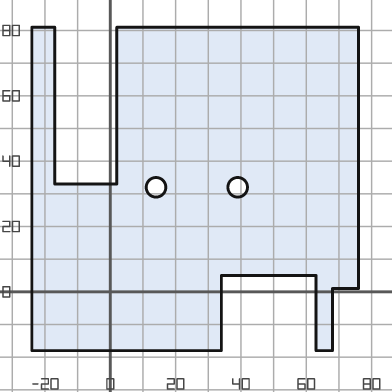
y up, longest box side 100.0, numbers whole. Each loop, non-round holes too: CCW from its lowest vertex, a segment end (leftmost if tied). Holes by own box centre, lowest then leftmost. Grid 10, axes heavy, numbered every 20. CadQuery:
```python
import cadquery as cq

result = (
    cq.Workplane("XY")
    .moveTo(-24.0, -18.0)
    .lineTo(34.0, -18.0)
    .lineTo(34.0, 5.0)
    .lineTo(63.0, 5.0)
    .lineTo(63.0, -18.0)
    .lineTo(68.0, -18.0)
    .lineTo(68.0, 1.0)
    .lineTo(76.0, 1.0)
    .lineTo(76.0, 81.0)
    .lineTo(2.0, 81.0)
    .lineTo(2.0, 33.0)
    .lineTo(-17.0, 33.0)
    .lineTo(-17.0, 81.0)
    .lineTo(-24.0, 81.0)
    .close()
    .moveTo(14.0, 32.0)
    .circle(3.0)
    .moveTo(39.0, 32.0)
    .circle(3.0)
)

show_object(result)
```